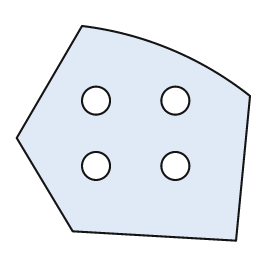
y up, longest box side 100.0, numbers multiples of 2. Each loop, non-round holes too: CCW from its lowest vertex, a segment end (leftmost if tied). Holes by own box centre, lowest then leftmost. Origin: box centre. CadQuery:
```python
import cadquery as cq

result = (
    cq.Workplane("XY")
    .moveTo(44.0, -46.0)
    .lineTo(50.0, 16.0)
    .threePointArc((16.0, 36.0), (-22.0, 46.0))
    .lineTo(-50.0, -2.0)
    .lineTo(-26.0, -42.0)
    .close()
    .moveTo(-16.0, -14.0)
    .circle(6.0)
    .moveTo(18.0, -14.0)
    .circle(6.0)
    .moveTo(-16.0, 14.0)
    .circle(6.0)
    .moveTo(18.0, 14.0)
    .circle(6.0)
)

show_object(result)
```